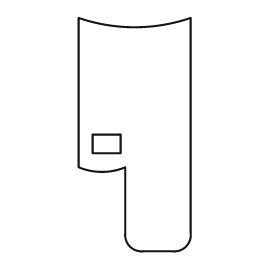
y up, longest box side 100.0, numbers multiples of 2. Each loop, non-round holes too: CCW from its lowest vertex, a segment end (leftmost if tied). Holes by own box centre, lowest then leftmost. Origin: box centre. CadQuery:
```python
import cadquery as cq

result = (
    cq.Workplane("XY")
    .moveTo(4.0, -50.0)
    .lineTo(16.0, -50.0)
    .threePointArc((22.0, -48.0), (24.0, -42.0))
    .lineTo(24.0, 50.0)
    .threePointArc((0.0, 46.0), (-24.0, 50.0))
    .lineTo(-24.0, -14.0)
    .threePointArc((-14.0, -16.0), (-4.0, -14.0))
    .lineTo(-4.0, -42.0)
    .threePointArc((-2.0, -48.0), (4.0, -50.0))
    .close()
    .moveTo(-18.0, -8.0)
    .lineTo(-6.0, -8.0)
    .lineTo(-6.0, 0.0)
    .lineTo(-18.0, 0.0)
    .close()
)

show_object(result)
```